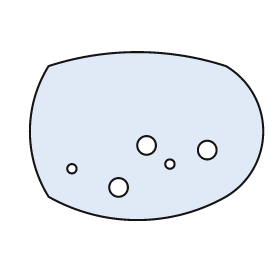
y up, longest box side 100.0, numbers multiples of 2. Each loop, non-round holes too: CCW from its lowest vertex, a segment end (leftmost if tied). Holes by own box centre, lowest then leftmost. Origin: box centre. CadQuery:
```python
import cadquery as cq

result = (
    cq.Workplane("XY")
    .moveTo(-42.0, -26.0)
    .threePointArc((-4.0, -36.0), (34.0, -26.0))
    .threePointArc((50.0, 2.0), (34.0, 30.0))
    .threePointArc((-4.0, 36.0), (-42.0, 30.0))
    .threePointArc((-50.0, 2.0), (-42.0, -26.0))
    .close()
    .moveTo(-12.0, -22.0)
    .circle(4.0)
    .moveTo(-32.0, -14.0)
    .circle(2.0)
    .moveTo(10.0, -12.0)
    .circle(2.0)
    .moveTo(26.0, -6.0)
    .circle(4.0)
    .moveTo(0.0, -4.0)
    .circle(4.0)
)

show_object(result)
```